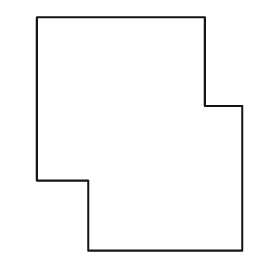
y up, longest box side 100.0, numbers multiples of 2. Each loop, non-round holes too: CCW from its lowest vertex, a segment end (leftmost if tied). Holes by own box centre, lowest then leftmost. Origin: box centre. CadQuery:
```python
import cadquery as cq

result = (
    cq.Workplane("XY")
    .moveTo(-22.0, -50.0)
    .lineTo(44.0, -50.0)
    .lineTo(44.0, 12.0)
    .lineTo(28.0, 12.0)
    .lineTo(28.0, 50.0)
    .lineTo(-44.0, 50.0)
    .lineTo(-44.0, -20.0)
    .lineTo(-22.0, -20.0)
    .close()
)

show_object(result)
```